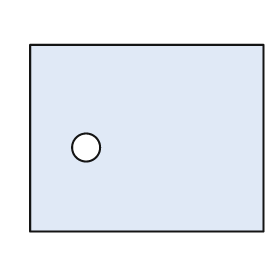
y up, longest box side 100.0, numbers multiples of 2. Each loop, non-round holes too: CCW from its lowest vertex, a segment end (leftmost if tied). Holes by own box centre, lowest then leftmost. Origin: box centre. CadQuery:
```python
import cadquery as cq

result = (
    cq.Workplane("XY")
    .moveTo(-50.0, -40.0)
    .lineTo(50.0, -40.0)
    .lineTo(50.0, 40.0)
    .lineTo(-50.0, 40.0)
    .close()
    .moveTo(-26.0, -4.0)
    .circle(6.0)
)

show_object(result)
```